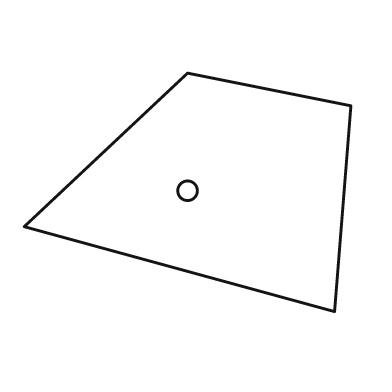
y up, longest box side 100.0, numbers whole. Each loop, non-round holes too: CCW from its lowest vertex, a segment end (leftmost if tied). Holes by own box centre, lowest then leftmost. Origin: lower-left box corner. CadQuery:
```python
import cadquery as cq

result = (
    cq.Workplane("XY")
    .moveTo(95.0, 0.0)
    .lineTo(100.0, 63.0)
    .lineTo(50.0, 73.0)
    .lineTo(0.0, 26.0)
    .close()
    .moveTo(50.0, 37.0)
    .circle(3.0)
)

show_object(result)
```